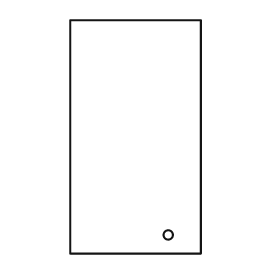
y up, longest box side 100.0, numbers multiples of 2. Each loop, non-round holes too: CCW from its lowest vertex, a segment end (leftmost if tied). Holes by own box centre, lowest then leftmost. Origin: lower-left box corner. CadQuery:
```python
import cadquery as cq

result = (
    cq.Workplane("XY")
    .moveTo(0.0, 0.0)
    .lineTo(56.0, 0.0)
    .lineTo(56.0, 100.0)
    .lineTo(0.0, 100.0)
    .close()
    .moveTo(42.0, 8.0)
    .circle(2.0)
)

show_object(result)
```